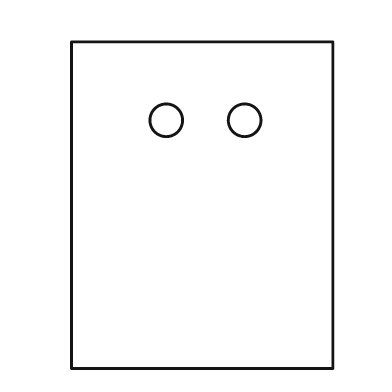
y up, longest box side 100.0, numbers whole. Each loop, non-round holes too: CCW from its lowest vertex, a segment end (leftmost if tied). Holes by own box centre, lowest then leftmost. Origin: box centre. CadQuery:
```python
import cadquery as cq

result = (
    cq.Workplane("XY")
    .moveTo(-40.0, -50.0)
    .lineTo(40.0, -50.0)
    .lineTo(40.0, 50.0)
    .lineTo(-40.0, 50.0)
    .close()
    .moveTo(-11.0, 26.0)
    .circle(5.0)
    .moveTo(13.0, 26.0)
    .circle(5.0)
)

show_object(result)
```